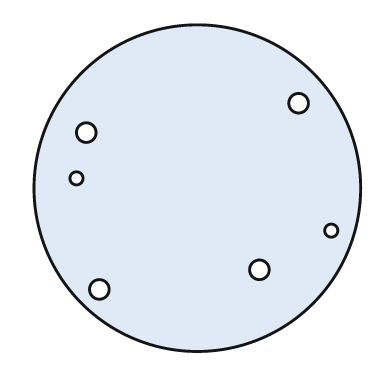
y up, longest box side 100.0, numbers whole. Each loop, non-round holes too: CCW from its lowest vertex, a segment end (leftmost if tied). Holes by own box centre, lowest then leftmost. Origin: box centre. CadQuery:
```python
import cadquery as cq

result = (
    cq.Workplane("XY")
    .moveTo(0.0, 0.0)
    .circle(50.0)
    .moveTo(-30.0, -31.0)
    .circle(3.0)
    .moveTo(19.0, -25.0)
    .circle(3.0)
    .moveTo(41.0, -13.0)
    .circle(2.0)
    .moveTo(-37.0, 3.0)
    .circle(2.0)
    .moveTo(-34.0, 17.0)
    .circle(3.0)
    .moveTo(31.0, 26.0)
    .circle(3.0)
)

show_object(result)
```